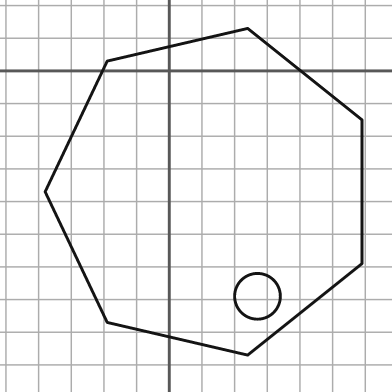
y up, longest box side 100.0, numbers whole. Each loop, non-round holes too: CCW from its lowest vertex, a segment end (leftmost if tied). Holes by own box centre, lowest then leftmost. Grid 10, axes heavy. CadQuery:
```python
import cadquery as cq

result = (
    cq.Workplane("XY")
    .moveTo(24.0, -87.0)
    .lineTo(59.0, -59.0)
    .lineTo(59.0, -15.0)
    .lineTo(24.0, 13.0)
    .lineTo(-19.0, 3.0)
    .lineTo(-38.0, -37.0)
    .lineTo(-19.0, -77.0)
    .close()
    .moveTo(27.0, -69.0)
    .circle(7.0)
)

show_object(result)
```